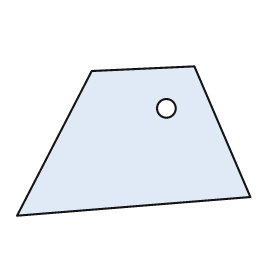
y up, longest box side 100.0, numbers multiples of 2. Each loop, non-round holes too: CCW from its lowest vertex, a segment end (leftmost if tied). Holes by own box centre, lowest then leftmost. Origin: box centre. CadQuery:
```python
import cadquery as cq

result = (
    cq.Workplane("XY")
    .moveTo(-50.0, -32.0)
    .lineTo(50.0, -24.0)
    .lineTo(26.0, 32.0)
    .lineTo(-18.0, 30.0)
    .close()
    .moveTo(14.0, 14.0)
    .circle(4.0)
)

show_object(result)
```